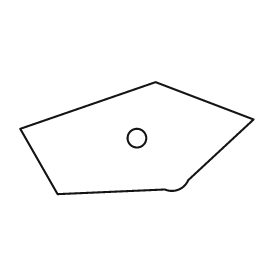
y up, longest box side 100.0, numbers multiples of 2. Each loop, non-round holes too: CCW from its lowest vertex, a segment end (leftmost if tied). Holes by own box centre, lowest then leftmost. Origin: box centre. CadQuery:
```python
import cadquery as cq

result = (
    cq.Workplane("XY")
    .moveTo(-34.0, -24.0)
    .lineTo(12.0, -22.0)
    .threePointArc((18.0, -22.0), (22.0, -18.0))
    .lineTo(50.0, 8.0)
    .lineTo(8.0, 24.0)
    .lineTo(-50.0, 4.0)
    .close()
    .moveTo(0.0, 0.0)
    .circle(4.0)
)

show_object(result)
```